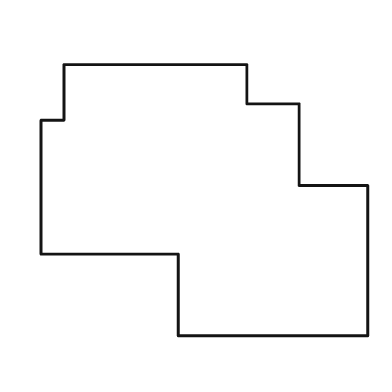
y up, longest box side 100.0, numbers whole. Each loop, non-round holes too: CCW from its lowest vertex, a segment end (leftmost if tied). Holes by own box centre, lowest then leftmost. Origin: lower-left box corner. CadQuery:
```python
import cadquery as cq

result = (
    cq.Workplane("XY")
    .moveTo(42.0, 0.0)
    .lineTo(100.0, 0.0)
    .lineTo(100.0, 46.0)
    .lineTo(79.0, 46.0)
    .lineTo(79.0, 71.0)
    .lineTo(63.0, 71.0)
    .lineTo(63.0, 83.0)
    .lineTo(7.0, 83.0)
    .lineTo(7.0, 66.0)
    .lineTo(0.0, 66.0)
    .lineTo(0.0, 25.0)
    .lineTo(42.0, 25.0)
    .close()
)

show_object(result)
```